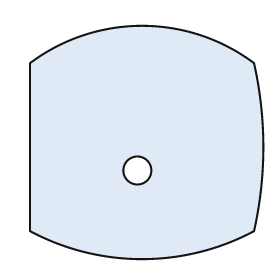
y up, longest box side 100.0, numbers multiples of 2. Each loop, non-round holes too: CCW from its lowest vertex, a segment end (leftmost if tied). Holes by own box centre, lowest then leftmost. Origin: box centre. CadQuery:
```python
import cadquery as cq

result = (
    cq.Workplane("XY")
    .moveTo(-50.0, -38.0)
    .threePointArc((-2.0, -50.0), (46.0, -38.0))
    .threePointArc((50.0, -2.0), (46.0, 34.0))
    .threePointArc((-2.0, 50.0), (-50.0, 34.0))
    .close()
    .moveTo(-4.0, -12.0)
    .circle(6.0)
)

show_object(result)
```